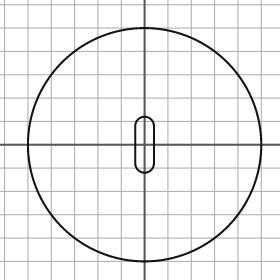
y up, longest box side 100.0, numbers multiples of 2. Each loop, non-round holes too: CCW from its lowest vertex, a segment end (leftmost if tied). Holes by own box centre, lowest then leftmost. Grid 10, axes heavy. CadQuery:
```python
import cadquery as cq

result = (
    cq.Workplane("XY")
    .moveTo(0.0, 0.0)
    .circle(50.0)
    .moveTo(-4.0, -8.0)
    .threePointArc((0.0, -12.0), (4.0, -8.0))
    .lineTo(4.0, 8.0)
    .threePointArc((0.0, 12.0), (-4.0, 8.0))
    .close()
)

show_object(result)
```